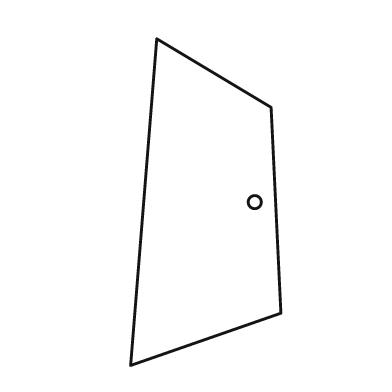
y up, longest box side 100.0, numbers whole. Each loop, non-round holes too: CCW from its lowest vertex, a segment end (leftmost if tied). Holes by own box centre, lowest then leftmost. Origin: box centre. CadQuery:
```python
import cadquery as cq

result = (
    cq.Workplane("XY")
    .moveTo(-23.0, -50.0)
    .lineTo(23.0, -34.0)
    .lineTo(20.0, 29.0)
    .lineTo(-15.0, 50.0)
    .close()
    .moveTo(15.0, 0.0)
    .circle(2.0)
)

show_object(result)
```